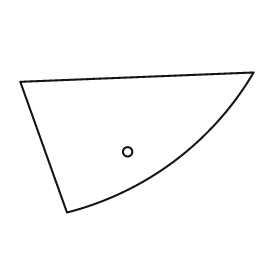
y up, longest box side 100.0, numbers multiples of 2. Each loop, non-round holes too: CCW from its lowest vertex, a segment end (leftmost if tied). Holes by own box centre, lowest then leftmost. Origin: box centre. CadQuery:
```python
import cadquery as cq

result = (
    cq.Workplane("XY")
    .moveTo(-30.0, -30.0)
    .threePointArc((16.0, -8.0), (50.0, 30.0))
    .lineTo(-50.0, 26.0)
    .close()
    .moveTo(-4.0, -4.0)
    .circle(2.0)
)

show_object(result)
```